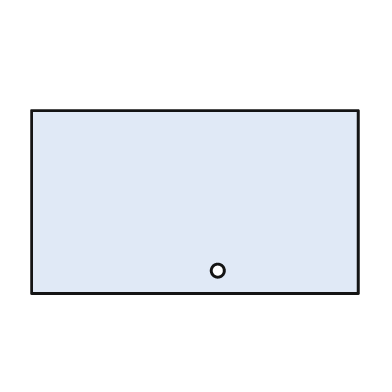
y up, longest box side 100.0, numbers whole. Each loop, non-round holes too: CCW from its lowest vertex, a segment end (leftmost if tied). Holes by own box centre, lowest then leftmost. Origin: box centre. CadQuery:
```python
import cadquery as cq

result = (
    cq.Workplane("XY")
    .moveTo(-50.0, -28.0)
    .lineTo(50.0, -28.0)
    .lineTo(50.0, 28.0)
    .lineTo(-50.0, 28.0)
    .close()
    .moveTo(7.0, -21.0)
    .circle(2.0)
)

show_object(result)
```